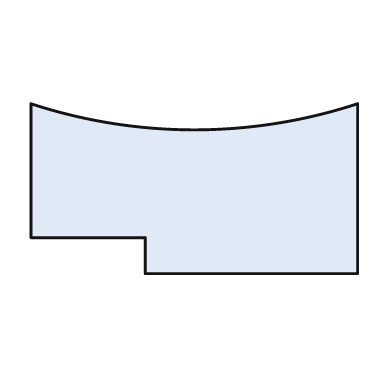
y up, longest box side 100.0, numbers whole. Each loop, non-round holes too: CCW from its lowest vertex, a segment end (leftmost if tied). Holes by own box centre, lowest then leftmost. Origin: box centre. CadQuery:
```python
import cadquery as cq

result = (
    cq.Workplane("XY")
    .moveTo(-15.0, -26.0)
    .lineTo(50.0, -26.0)
    .lineTo(50.0, 26.0)
    .threePointArc((0.0, 18.0), (-50.0, 26.0))
    .lineTo(-50.0, -15.0)
    .lineTo(-15.0, -15.0)
    .close()
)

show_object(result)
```